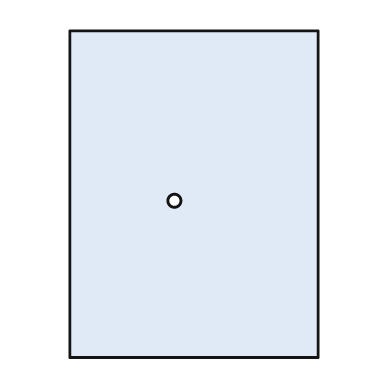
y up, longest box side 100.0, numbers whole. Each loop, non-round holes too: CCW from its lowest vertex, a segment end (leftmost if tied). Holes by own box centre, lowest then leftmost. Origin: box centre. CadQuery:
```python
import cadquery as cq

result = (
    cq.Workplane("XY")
    .moveTo(-38.0, -50.0)
    .lineTo(38.0, -50.0)
    .lineTo(38.0, 50.0)
    .lineTo(-38.0, 50.0)
    .close()
    .moveTo(-6.0, -2.0)
    .circle(2.0)
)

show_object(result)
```